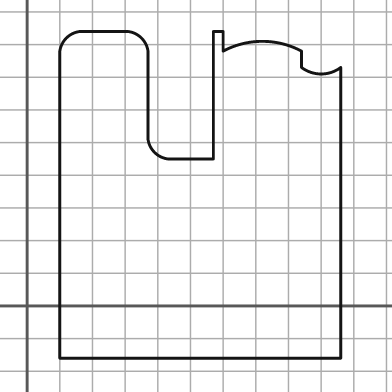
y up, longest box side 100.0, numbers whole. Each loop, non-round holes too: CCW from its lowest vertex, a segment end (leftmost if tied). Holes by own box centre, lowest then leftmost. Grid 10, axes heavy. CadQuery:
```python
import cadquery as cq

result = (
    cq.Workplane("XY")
    .moveTo(10.0, -16.0)
    .lineTo(96.0, -16.0)
    .lineTo(96.0, 73.0)
    .threePointArc((90.0, 71.0), (84.0, 73.0))
    .lineTo(84.0, 78.0)
    .threePointArc((72.0, 81.0), (60.0, 78.0))
    .lineTo(60.0, 84.0)
    .lineTo(57.0, 84.0)
    .lineTo(57.0, 45.0)
    .lineTo(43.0, 45.0)
    .threePointArc((39.0, 47.0), (37.0, 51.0))
    .lineTo(37.0, 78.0)
    .threePointArc((35.0, 82.0), (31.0, 84.0))
    .lineTo(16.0, 84.0)
    .threePointArc((12.0, 82.0), (10.0, 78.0))
    .close()
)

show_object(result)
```